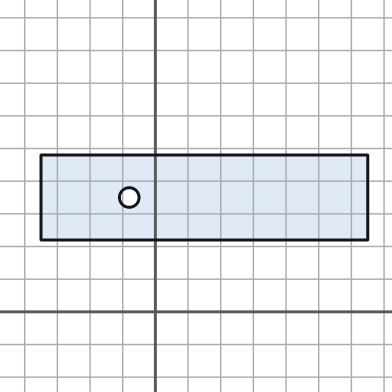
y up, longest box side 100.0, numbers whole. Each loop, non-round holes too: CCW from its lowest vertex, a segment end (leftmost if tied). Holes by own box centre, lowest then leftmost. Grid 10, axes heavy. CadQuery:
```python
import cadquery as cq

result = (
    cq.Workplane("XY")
    .moveTo(-35.0, 22.0)
    .lineTo(65.0, 22.0)
    .lineTo(65.0, 48.0)
    .lineTo(-35.0, 48.0)
    .close()
    .moveTo(-8.0, 35.0)
    .circle(3.0)
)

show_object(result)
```